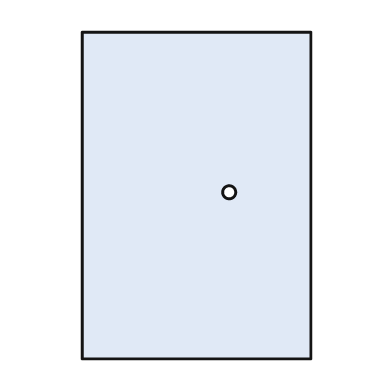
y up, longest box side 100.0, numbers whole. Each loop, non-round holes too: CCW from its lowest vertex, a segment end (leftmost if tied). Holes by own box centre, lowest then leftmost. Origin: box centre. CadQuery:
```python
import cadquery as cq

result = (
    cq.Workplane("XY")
    .moveTo(-35.0, -50.0)
    .lineTo(35.0, -50.0)
    .lineTo(35.0, 50.0)
    .lineTo(-35.0, 50.0)
    .close()
    .moveTo(10.0, 1.0)
    .circle(2.0)
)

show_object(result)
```